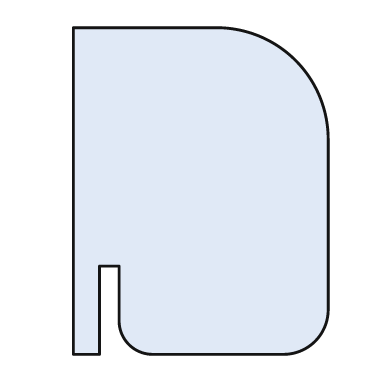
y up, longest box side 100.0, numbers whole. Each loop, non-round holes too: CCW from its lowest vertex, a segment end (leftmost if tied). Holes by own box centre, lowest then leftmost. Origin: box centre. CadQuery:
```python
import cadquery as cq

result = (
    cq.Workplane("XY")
    .moveTo(-39.0, -50.0)
    .lineTo(-31.0, -50.0)
    .lineTo(-31.0, -23.0)
    .lineTo(-25.0, -23.0)
    .lineTo(-25.0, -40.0)
    .threePointArc((-22.0, -47.0), (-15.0, -50.0))
    .lineTo(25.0, -50.0)
    .threePointArc((35.0, -46.0), (39.0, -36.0))
    .lineTo(39.0, 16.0)
    .threePointArc((29.0, 40.0), (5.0, 50.0))
    .lineTo(-39.0, 50.0)
    .close()
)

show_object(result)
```